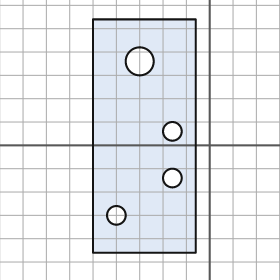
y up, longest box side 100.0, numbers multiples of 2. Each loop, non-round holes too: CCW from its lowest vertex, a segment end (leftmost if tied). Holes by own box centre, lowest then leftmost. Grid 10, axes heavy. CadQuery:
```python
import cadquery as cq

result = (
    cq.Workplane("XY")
    .moveTo(-50.0, -46.0)
    .lineTo(-6.0, -46.0)
    .lineTo(-6.0, 54.0)
    .lineTo(-50.0, 54.0)
    .close()
    .moveTo(-40.0, -30.0)
    .circle(4.0)
    .moveTo(-16.0, -14.0)
    .circle(4.0)
    .moveTo(-16.0, 6.0)
    .circle(4.0)
    .moveTo(-30.0, 36.0)
    .circle(6.0)
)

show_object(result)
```